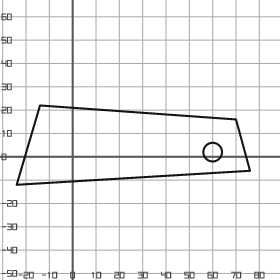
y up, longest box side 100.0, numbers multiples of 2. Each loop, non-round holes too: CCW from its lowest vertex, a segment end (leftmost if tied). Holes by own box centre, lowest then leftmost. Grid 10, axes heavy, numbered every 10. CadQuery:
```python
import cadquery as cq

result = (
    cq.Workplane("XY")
    .moveTo(-24.0, -12.0)
    .lineTo(76.0, -6.0)
    .lineTo(70.0, 16.0)
    .lineTo(-14.0, 22.0)
    .close()
    .moveTo(60.0, 2.0)
    .circle(4.0)
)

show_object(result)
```